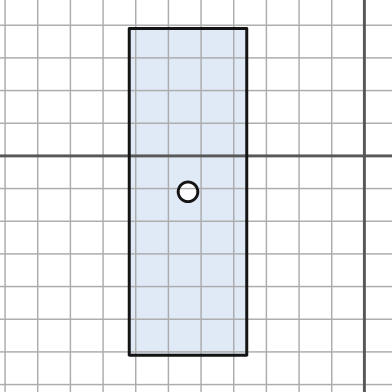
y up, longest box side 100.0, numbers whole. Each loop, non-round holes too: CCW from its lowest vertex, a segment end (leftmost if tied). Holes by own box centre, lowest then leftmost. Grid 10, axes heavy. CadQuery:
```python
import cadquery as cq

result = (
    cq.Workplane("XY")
    .moveTo(-72.0, -61.0)
    .lineTo(-36.0, -61.0)
    .lineTo(-36.0, 39.0)
    .lineTo(-72.0, 39.0)
    .close()
    .moveTo(-54.0, -11.0)
    .circle(3.0)
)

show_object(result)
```